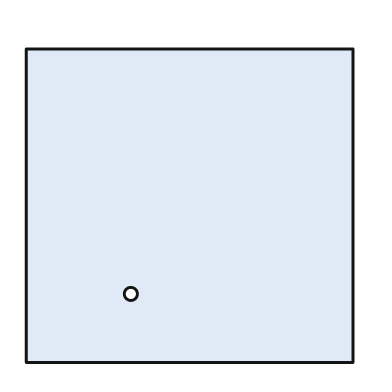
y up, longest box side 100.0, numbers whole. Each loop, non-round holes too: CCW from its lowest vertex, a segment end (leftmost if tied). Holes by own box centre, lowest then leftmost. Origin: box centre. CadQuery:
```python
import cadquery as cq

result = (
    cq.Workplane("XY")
    .moveTo(-50.0, -48.0)
    .lineTo(50.0, -48.0)
    .lineTo(50.0, 48.0)
    .lineTo(-50.0, 48.0)
    .close()
    .moveTo(-18.0, -27.0)
    .circle(2.0)
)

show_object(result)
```